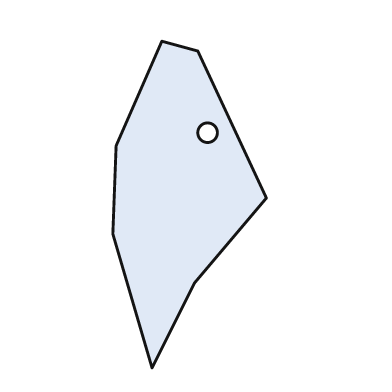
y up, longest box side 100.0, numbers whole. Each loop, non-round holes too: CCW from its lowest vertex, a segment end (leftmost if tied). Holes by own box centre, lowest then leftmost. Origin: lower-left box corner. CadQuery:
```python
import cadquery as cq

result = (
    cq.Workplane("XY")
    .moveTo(12.0, 0.0)
    .lineTo(25.0, 26.0)
    .lineTo(47.0, 52.0)
    .lineTo(26.0, 97.0)
    .lineTo(15.0, 100.0)
    .lineTo(1.0, 68.0)
    .lineTo(0.0, 41.0)
    .close()
    .moveTo(29.0, 72.0)
    .circle(3.0)
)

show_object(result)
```